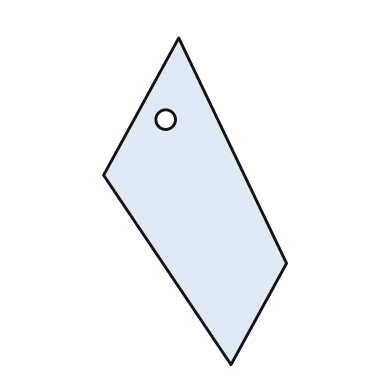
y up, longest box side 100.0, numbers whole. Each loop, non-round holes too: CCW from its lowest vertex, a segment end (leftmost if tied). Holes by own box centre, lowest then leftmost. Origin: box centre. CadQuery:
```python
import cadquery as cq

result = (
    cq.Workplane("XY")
    .moveTo(11.0, -50.0)
    .lineTo(28.0, -19.0)
    .lineTo(-5.0, 50.0)
    .lineTo(-28.0, 8.0)
    .close()
    .moveTo(-9.0, 25.0)
    .circle(3.0)
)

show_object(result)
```